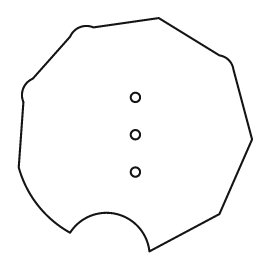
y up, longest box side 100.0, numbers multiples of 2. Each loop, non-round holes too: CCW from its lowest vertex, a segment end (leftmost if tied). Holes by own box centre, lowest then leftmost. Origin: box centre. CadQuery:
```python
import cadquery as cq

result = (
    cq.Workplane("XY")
    .moveTo(6.0, -50.0)
    .lineTo(36.0, -34.0)
    .lineTo(50.0, -2.0)
    .lineTo(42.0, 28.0)
    .threePointArc((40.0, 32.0), (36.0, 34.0))
    .lineTo(10.0, 50.0)
    .lineTo(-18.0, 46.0)
    .threePointArc((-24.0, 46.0), (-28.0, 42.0))
    .lineTo(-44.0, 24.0)
    .threePointArc((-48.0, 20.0), (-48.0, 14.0))
    .lineTo(-50.0, -14.0)
    .threePointArc((-42.0, -30.0), (-28.0, -42.0))
    .threePointArc((-8.0, -34.0), (6.0, -50.0))
    .close()
    .moveTo(0.0, -16.0)
    .circle(2.0)
    .moveTo(0.0, 0.0)
    .circle(2.0)
    .moveTo(0.0, 16.0)
    .circle(2.0)
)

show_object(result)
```